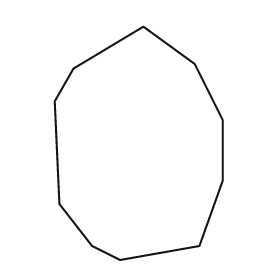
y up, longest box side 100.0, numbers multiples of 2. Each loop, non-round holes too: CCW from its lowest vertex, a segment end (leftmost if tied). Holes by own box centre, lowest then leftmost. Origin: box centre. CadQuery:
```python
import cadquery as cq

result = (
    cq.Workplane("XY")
    .moveTo(-8.0, -50.0)
    .lineTo(26.0, -44.0)
    .lineTo(36.0, -16.0)
    .lineTo(36.0, 10.0)
    .lineTo(24.0, 34.0)
    .lineTo(2.0, 50.0)
    .lineTo(-28.0, 32.0)
    .lineTo(-36.0, 18.0)
    .lineTo(-34.0, -26.0)
    .lineTo(-20.0, -44.0)
    .close()
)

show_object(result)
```